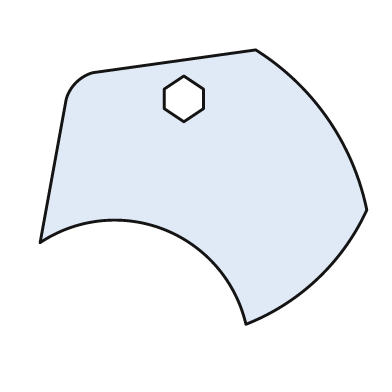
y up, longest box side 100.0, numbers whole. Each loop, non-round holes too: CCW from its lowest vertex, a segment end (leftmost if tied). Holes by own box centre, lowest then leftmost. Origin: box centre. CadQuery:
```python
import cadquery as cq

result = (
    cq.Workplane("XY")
    .moveTo(13.0, -42.0)
    .threePointArc((35.0, -28.0), (50.0, -7.0))
    .threePointArc((38.0, 21.0), (16.0, 42.0))
    .lineTo(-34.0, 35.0)
    .threePointArc((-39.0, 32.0), (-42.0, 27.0))
    .lineTo(-50.0, -17.0)
    .threePointArc((-12.0, -13.0), (13.0, -42.0))
    .close()
    .moveTo(-6.0, 20.0)
    .lineTo(0.0, 24.0)
    .lineTo(0.0, 30.0)
    .lineTo(-6.0, 34.0)
    .lineTo(-12.0, 30.0)
    .lineTo(-12.0, 24.0)
    .close()
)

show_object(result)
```